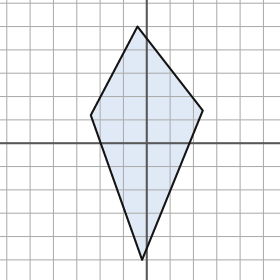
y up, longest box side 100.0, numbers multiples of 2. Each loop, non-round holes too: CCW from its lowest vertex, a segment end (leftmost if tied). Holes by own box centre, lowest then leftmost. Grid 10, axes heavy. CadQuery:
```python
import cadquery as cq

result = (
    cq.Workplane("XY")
    .moveTo(-2.0, -50.0)
    .lineTo(24.0, 14.0)
    .lineTo(-4.0, 50.0)
    .lineTo(-24.0, 12.0)
    .close()
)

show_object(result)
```